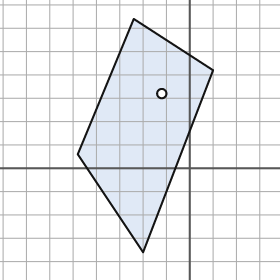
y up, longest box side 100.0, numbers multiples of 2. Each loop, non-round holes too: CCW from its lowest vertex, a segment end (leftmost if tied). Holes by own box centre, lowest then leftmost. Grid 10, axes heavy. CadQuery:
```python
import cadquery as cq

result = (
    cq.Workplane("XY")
    .moveTo(-20.0, -36.0)
    .lineTo(10.0, 42.0)
    .lineTo(-24.0, 64.0)
    .lineTo(-48.0, 6.0)
    .close()
    .moveTo(-12.0, 32.0)
    .circle(2.0)
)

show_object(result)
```